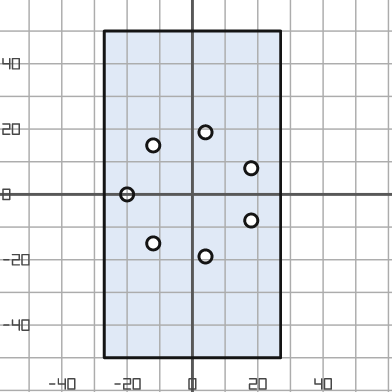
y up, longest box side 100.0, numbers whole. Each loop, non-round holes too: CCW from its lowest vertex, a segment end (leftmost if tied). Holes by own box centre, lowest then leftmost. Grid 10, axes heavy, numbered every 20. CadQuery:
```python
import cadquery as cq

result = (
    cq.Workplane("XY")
    .moveTo(-27.0, -50.0)
    .lineTo(27.0, -50.0)
    .lineTo(27.0, 50.0)
    .lineTo(-27.0, 50.0)
    .close()
    .moveTo(4.0, -19.0)
    .circle(2.0)
    .moveTo(-12.0, -15.0)
    .circle(2.0)
    .moveTo(18.0, -8.0)
    .circle(2.0)
    .moveTo(-20.0, 0.0)
    .circle(2.0)
    .moveTo(18.0, 8.0)
    .circle(2.0)
    .moveTo(-12.0, 15.0)
    .circle(2.0)
    .moveTo(4.0, 19.0)
    .circle(2.0)
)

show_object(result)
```